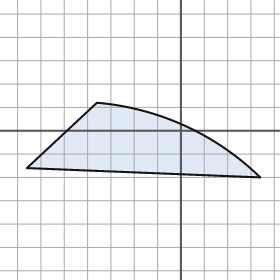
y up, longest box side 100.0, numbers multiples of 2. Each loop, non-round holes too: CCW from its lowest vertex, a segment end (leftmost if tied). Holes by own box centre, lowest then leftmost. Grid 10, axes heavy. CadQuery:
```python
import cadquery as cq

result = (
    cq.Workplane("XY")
    .moveTo(34.0, -20.0)
    .threePointArc((2.0, 2.0), (-36.0, 12.0))
    .lineTo(-66.0, -16.0)
    .close()
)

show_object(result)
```